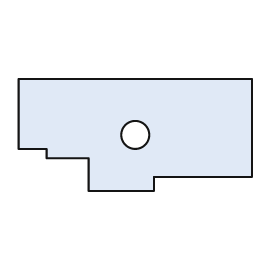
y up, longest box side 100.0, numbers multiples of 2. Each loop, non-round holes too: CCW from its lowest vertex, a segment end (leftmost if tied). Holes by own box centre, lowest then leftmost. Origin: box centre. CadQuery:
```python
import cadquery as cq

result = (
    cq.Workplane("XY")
    .moveTo(-20.0, -24.0)
    .lineTo(8.0, -24.0)
    .lineTo(8.0, -18.0)
    .lineTo(50.0, -18.0)
    .lineTo(50.0, 24.0)
    .lineTo(-50.0, 24.0)
    .lineTo(-50.0, -6.0)
    .lineTo(-38.0, -6.0)
    .lineTo(-38.0, -10.0)
    .lineTo(-20.0, -10.0)
    .close()
    .moveTo(0.0, 0.0)
    .circle(6.0)
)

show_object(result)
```